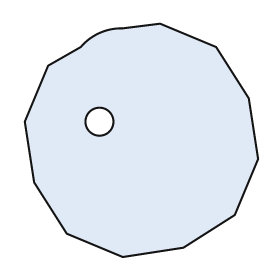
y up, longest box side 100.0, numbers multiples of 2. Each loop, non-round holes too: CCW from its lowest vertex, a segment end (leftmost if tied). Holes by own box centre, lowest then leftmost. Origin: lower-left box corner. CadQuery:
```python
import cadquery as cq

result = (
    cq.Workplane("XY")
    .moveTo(42.0, 0.0)
    .lineTo(68.0, 4.0)
    .lineTo(90.0, 18.0)
    .lineTo(100.0, 42.0)
    .lineTo(96.0, 68.0)
    .lineTo(82.0, 90.0)
    .lineTo(58.0, 100.0)
    .lineTo(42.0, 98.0)
    .threePointArc((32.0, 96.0), (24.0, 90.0))
    .lineTo(10.0, 82.0)
    .lineTo(0.0, 58.0)
    .lineTo(4.0, 32.0)
    .lineTo(18.0, 10.0)
    .close()
    .moveTo(32.0, 58.0)
    .circle(6.0)
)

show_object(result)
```